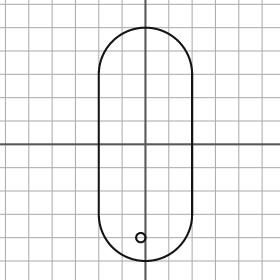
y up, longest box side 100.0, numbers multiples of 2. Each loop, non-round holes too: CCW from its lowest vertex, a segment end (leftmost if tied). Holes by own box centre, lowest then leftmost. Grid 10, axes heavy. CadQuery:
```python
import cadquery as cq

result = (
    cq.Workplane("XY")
    .moveTo(-20.0, -30.0)
    .threePointArc((0.0, -50.0), (20.0, -30.0))
    .lineTo(20.0, 30.0)
    .threePointArc((0.0, 50.0), (-20.0, 30.0))
    .close()
    .moveTo(-2.0, -40.0)
    .circle(2.0)
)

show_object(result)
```